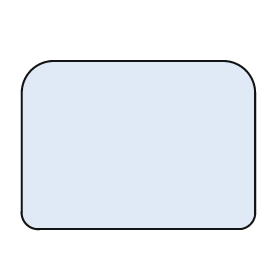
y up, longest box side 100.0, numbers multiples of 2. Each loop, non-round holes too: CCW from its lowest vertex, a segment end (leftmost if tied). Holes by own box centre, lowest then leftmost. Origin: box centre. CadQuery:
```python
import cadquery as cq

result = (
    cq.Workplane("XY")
    .moveTo(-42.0, -36.0)
    .lineTo(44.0, -36.0)
    .threePointArc((48.0, -34.0), (50.0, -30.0))
    .lineTo(50.0, 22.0)
    .threePointArc((46.0, 32.0), (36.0, 36.0))
    .lineTo(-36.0, 36.0)
    .threePointArc((-46.0, 32.0), (-50.0, 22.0))
    .lineTo(-50.0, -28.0)
    .threePointArc((-48.0, -34.0), (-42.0, -36.0))
    .close()
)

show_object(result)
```